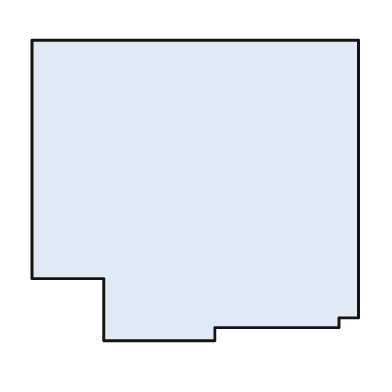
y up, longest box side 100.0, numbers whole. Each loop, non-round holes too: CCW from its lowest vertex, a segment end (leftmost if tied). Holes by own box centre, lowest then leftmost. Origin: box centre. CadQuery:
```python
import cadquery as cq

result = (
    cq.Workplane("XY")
    .moveTo(-28.0, -46.0)
    .lineTo(6.0, -46.0)
    .lineTo(6.0, -42.0)
    .lineTo(44.0, -42.0)
    .lineTo(44.0, -39.0)
    .lineTo(50.0, -39.0)
    .lineTo(50.0, 46.0)
    .lineTo(-50.0, 46.0)
    .lineTo(-50.0, -27.0)
    .lineTo(-28.0, -27.0)
    .close()
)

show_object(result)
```